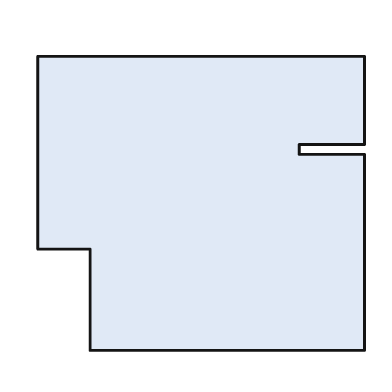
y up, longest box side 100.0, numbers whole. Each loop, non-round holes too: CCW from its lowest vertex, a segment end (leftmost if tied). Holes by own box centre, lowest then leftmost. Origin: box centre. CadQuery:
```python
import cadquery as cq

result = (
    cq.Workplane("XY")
    .moveTo(-34.0, -45.0)
    .lineTo(50.0, -45.0)
    .lineTo(50.0, 15.0)
    .lineTo(30.0, 15.0)
    .lineTo(30.0, 18.0)
    .lineTo(50.0, 18.0)
    .lineTo(50.0, 45.0)
    .lineTo(-50.0, 45.0)
    .lineTo(-50.0, -14.0)
    .lineTo(-34.0, -14.0)
    .close()
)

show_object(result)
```